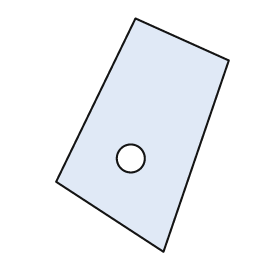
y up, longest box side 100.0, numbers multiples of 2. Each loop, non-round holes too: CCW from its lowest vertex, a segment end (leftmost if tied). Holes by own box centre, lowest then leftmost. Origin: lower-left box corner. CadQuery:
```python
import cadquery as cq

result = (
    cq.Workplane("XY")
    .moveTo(46.0, 0.0)
    .lineTo(74.0, 82.0)
    .lineTo(34.0, 100.0)
    .lineTo(0.0, 30.0)
    .close()
    .moveTo(32.0, 40.0)
    .circle(6.0)
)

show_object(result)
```